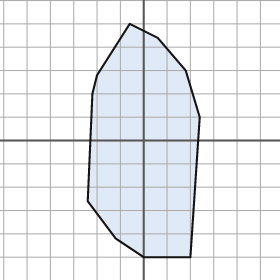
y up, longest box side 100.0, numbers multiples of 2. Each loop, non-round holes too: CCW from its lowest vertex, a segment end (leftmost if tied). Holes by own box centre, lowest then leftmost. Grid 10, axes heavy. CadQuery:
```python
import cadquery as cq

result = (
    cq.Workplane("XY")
    .moveTo(0.0, -50.0)
    .lineTo(20.0, -50.0)
    .lineTo(24.0, 10.0)
    .lineTo(18.0, 30.0)
    .lineTo(6.0, 44.0)
    .lineTo(-6.0, 50.0)
    .lineTo(-20.0, 28.0)
    .lineTo(-22.0, 20.0)
    .lineTo(-24.0, -26.0)
    .lineTo(-12.0, -42.0)
    .close()
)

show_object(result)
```